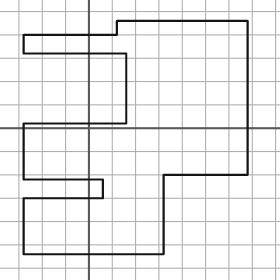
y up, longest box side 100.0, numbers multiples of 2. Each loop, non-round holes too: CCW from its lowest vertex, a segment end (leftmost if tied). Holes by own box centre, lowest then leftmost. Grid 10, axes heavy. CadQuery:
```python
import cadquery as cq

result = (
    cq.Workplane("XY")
    .moveTo(-28.0, -54.0)
    .lineTo(32.0, -54.0)
    .lineTo(32.0, -20.0)
    .lineTo(68.0, -20.0)
    .lineTo(68.0, 46.0)
    .lineTo(12.0, 46.0)
    .lineTo(12.0, 40.0)
    .lineTo(-28.0, 40.0)
    .lineTo(-28.0, 32.0)
    .lineTo(16.0, 32.0)
    .lineTo(16.0, 2.0)
    .lineTo(-28.0, 2.0)
    .lineTo(-28.0, -22.0)
    .lineTo(6.0, -22.0)
    .lineTo(6.0, -30.0)
    .lineTo(-28.0, -30.0)
    .close()
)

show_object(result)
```